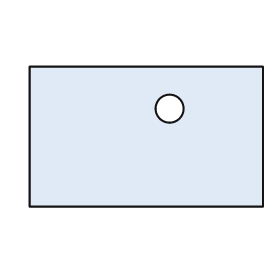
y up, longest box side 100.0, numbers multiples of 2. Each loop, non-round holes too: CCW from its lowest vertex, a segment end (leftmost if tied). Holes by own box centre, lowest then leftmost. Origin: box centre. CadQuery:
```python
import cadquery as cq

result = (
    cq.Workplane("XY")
    .moveTo(-50.0, -30.0)
    .lineTo(50.0, -30.0)
    .lineTo(50.0, 30.0)
    .lineTo(-50.0, 30.0)
    .close()
    .moveTo(10.0, 12.0)
    .circle(6.0)
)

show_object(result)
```